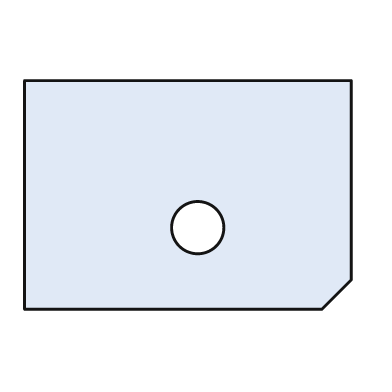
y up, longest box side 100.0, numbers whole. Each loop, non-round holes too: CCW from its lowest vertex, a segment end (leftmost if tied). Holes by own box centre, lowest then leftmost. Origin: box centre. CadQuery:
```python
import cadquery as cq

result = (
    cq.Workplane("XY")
    .moveTo(-50.0, -35.0)
    .lineTo(41.0, -35.0)
    .lineTo(50.0, -26.0)
    .lineTo(50.0, 35.0)
    .lineTo(-50.0, 35.0)
    .close()
    .moveTo(3.0, -10.0)
    .circle(8.0)
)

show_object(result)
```